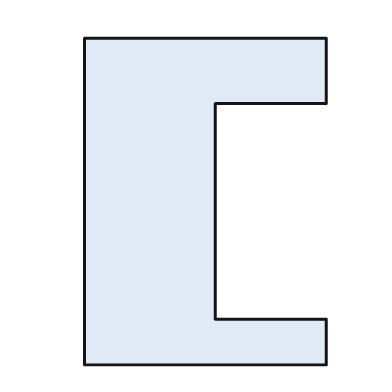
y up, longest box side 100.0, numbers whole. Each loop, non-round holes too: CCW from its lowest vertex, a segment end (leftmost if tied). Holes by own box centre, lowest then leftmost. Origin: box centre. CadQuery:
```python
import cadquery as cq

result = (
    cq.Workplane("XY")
    .moveTo(-37.0, -50.0)
    .lineTo(37.0, -50.0)
    .lineTo(37.0, -36.0)
    .lineTo(3.0, -36.0)
    .lineTo(3.0, 30.0)
    .lineTo(37.0, 30.0)
    .lineTo(37.0, 50.0)
    .lineTo(-37.0, 50.0)
    .close()
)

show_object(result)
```